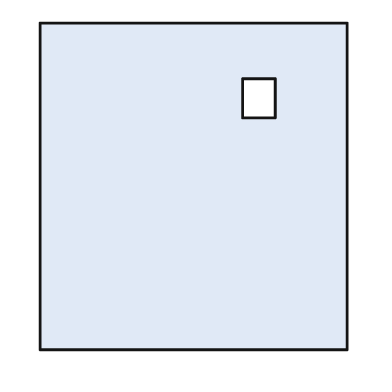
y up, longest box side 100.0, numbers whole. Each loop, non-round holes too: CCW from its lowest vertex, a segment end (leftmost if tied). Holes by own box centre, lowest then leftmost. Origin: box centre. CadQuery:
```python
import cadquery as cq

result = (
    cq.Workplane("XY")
    .moveTo(-47.0, -50.0)
    .lineTo(47.0, -50.0)
    .lineTo(47.0, 50.0)
    .lineTo(-47.0, 50.0)
    .close()
    .moveTo(15.0, 21.0)
    .lineTo(25.0, 21.0)
    .lineTo(25.0, 33.0)
    .lineTo(15.0, 33.0)
    .close()
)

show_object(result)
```